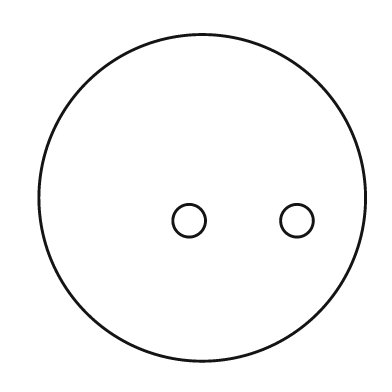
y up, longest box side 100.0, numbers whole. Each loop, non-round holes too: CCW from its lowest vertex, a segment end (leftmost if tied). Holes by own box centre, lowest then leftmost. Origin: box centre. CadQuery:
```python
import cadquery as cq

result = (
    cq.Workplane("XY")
    .moveTo(0.0, 0.0)
    .circle(50.0)
    .moveTo(-4.0, -7.0)
    .circle(5.0)
    .moveTo(29.0, -7.0)
    .circle(5.0)
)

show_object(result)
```